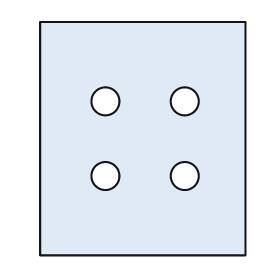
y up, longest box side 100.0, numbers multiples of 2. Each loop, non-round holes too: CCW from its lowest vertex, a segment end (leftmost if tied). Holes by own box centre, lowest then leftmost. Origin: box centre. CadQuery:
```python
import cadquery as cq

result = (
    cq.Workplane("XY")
    .moveTo(-44.0, -50.0)
    .lineTo(44.0, -50.0)
    .lineTo(44.0, 50.0)
    .lineTo(-44.0, 50.0)
    .close()
    .moveTo(-16.0, -16.0)
    .circle(6.0)
    .moveTo(18.0, -16.0)
    .circle(6.0)
    .moveTo(-16.0, 16.0)
    .circle(6.0)
    .moveTo(18.0, 16.0)
    .circle(6.0)
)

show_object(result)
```